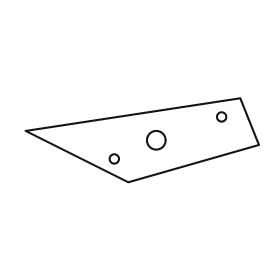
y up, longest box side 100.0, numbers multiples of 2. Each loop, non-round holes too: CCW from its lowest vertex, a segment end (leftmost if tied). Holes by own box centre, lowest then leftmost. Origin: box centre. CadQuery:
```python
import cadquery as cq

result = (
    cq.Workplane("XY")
    .moveTo(-6.0, -18.0)
    .lineTo(50.0, -2.0)
    .lineTo(42.0, 18.0)
    .lineTo(-50.0, 4.0)
    .close()
    .moveTo(-12.0, -8.0)
    .circle(2.0)
    .moveTo(6.0, 0.0)
    .circle(4.0)
    .moveTo(34.0, 10.0)
    .circle(2.0)
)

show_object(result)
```